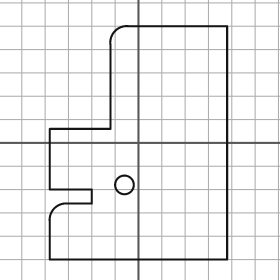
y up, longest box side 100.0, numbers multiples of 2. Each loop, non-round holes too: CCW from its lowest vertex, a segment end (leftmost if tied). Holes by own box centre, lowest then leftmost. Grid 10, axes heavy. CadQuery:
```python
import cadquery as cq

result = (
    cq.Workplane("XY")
    .moveTo(-38.0, -50.0)
    .lineTo(38.0, -50.0)
    .lineTo(38.0, 50.0)
    .lineTo(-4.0, 50.0)
    .threePointArc((-10.0, 48.0), (-12.0, 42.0))
    .lineTo(-12.0, 6.0)
    .lineTo(-38.0, 6.0)
    .lineTo(-38.0, -20.0)
    .lineTo(-20.0, -20.0)
    .lineTo(-20.0, -26.0)
    .lineTo(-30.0, -26.0)
    .threePointArc((-36.0, -28.0), (-38.0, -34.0))
    .close()
    .moveTo(-6.0, -18.0)
    .circle(4.0)
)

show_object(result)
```